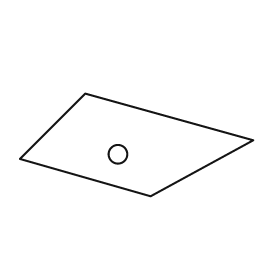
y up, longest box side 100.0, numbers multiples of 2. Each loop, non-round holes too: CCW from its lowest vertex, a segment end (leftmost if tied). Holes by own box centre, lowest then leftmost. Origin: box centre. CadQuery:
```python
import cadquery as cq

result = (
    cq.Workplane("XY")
    .moveTo(6.0, -22.0)
    .lineTo(50.0, 2.0)
    .lineTo(-22.0, 22.0)
    .lineTo(-50.0, -6.0)
    .close()
    .moveTo(-8.0, -4.0)
    .circle(4.0)
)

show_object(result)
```